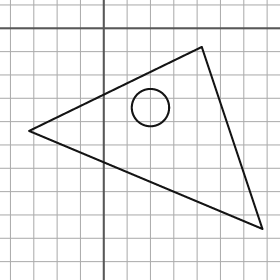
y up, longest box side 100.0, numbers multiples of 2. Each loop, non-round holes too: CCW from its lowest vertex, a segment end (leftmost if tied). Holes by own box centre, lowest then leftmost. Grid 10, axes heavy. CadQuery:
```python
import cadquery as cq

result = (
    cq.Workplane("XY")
    .moveTo(68.0, -86.0)
    .lineTo(42.0, -8.0)
    .lineTo(-32.0, -44.0)
    .close()
    .moveTo(20.0, -34.0)
    .circle(8.0)
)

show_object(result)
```